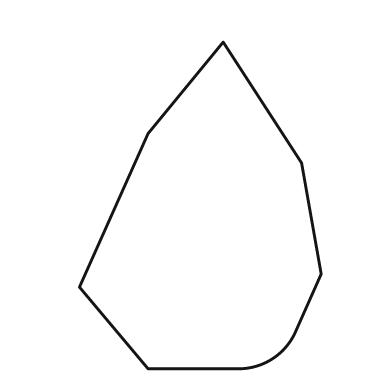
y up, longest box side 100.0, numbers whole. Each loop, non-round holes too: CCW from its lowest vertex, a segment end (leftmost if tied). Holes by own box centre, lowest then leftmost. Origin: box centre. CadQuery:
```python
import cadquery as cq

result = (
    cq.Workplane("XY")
    .moveTo(-16.0, -50.0)
    .lineTo(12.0, -50.0)
    .threePointArc((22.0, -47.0), (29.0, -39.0))
    .lineTo(37.0, -21.0)
    .lineTo(31.0, 13.0)
    .lineTo(7.0, 50.0)
    .lineTo(-16.0, 22.0)
    .lineTo(-37.0, -25.0)
    .close()
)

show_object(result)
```